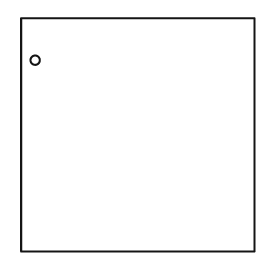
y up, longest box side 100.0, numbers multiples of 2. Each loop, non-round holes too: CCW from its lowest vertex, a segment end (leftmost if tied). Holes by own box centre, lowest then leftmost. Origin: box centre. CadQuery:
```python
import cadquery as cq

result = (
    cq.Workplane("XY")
    .moveTo(-50.0, -50.0)
    .lineTo(50.0, -50.0)
    .lineTo(50.0, 50.0)
    .lineTo(-50.0, 50.0)
    .close()
    .moveTo(-44.0, 32.0)
    .circle(2.0)
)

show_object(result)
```